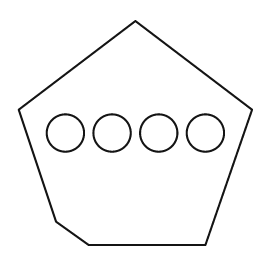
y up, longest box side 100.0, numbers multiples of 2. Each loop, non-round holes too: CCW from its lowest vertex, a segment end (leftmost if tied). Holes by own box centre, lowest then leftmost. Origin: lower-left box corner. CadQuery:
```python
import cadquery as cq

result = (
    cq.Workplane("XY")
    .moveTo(30.0, 0.0)
    .lineTo(80.0, 0.0)
    .lineTo(100.0, 58.0)
    .lineTo(50.0, 96.0)
    .lineTo(0.0, 58.0)
    .lineTo(16.0, 10.0)
    .close()
    .moveTo(20.0, 48.0)
    .circle(8.0)
    .moveTo(40.0, 48.0)
    .circle(8.0)
    .moveTo(60.0, 48.0)
    .circle(8.0)
    .moveTo(80.0, 48.0)
    .circle(8.0)
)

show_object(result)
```